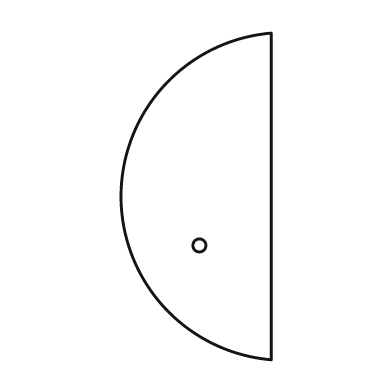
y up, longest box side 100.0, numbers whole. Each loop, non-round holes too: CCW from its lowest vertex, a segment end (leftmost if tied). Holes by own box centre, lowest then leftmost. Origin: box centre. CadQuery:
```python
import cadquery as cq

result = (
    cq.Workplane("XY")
    .moveTo(23.0, -50.0)
    .lineTo(23.0, 50.0)
    .threePointArc((-23.0, 0.0), (23.0, -50.0))
    .close()
    .moveTo(1.0, -15.0)
    .circle(2.0)
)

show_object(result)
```